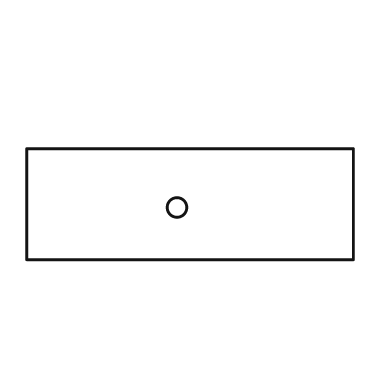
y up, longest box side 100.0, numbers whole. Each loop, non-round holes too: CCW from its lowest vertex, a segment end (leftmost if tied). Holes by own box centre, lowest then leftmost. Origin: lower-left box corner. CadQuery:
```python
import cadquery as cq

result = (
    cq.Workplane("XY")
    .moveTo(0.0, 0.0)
    .lineTo(100.0, 0.0)
    .lineTo(100.0, 34.0)
    .lineTo(0.0, 34.0)
    .close()
    .moveTo(46.0, 16.0)
    .circle(3.0)
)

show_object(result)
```